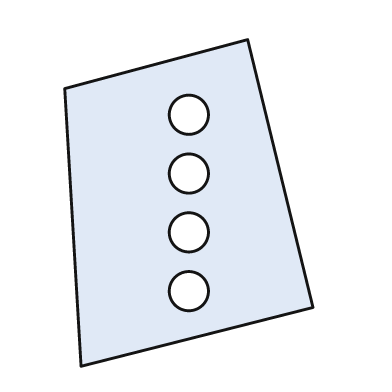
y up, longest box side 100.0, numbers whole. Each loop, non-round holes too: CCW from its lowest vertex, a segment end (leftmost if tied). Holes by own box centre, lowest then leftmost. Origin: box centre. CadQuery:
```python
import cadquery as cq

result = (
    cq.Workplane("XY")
    .moveTo(-33.0, -50.0)
    .lineTo(38.0, -32.0)
    .lineTo(18.0, 50.0)
    .lineTo(-38.0, 35.0)
    .close()
    .moveTo(0.0, -27.0)
    .circle(6.0)
    .moveTo(0.0, -9.0)
    .circle(6.0)
    .moveTo(0.0, 9.0)
    .circle(6.0)
    .moveTo(0.0, 27.0)
    .circle(6.0)
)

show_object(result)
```